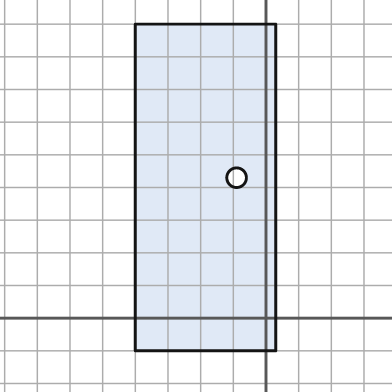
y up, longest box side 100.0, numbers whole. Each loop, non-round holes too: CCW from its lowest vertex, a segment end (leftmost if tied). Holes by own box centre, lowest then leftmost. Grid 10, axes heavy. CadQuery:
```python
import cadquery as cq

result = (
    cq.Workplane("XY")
    .moveTo(-40.0, -10.0)
    .lineTo(3.0, -10.0)
    .lineTo(3.0, 90.0)
    .lineTo(-40.0, 90.0)
    .close()
    .moveTo(-9.0, 43.0)
    .circle(3.0)
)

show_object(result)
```